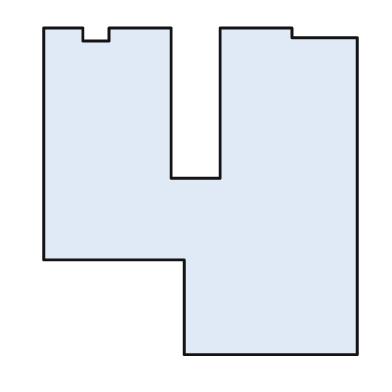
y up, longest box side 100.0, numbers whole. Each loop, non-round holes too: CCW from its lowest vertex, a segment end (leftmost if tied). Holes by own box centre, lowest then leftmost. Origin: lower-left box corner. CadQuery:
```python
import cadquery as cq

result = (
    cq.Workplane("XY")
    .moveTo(43.0, 0.0)
    .lineTo(96.0, 0.0)
    .lineTo(96.0, 97.0)
    .lineTo(76.0, 97.0)
    .lineTo(76.0, 100.0)
    .lineTo(54.0, 100.0)
    .lineTo(54.0, 54.0)
    .lineTo(39.0, 54.0)
    .lineTo(39.0, 100.0)
    .lineTo(20.0, 100.0)
    .lineTo(20.0, 96.0)
    .lineTo(12.0, 96.0)
    .lineTo(12.0, 100.0)
    .lineTo(0.0, 100.0)
    .lineTo(0.0, 29.0)
    .lineTo(43.0, 29.0)
    .close()
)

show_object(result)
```